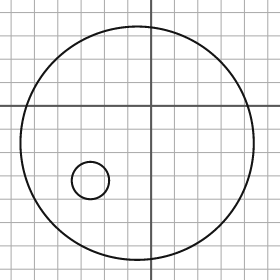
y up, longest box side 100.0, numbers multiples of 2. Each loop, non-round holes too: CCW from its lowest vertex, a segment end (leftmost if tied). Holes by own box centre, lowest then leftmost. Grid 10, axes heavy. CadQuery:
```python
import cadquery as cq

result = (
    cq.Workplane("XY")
    .moveTo(-6.0, -16.0)
    .circle(50.0)
    .moveTo(-26.0, -32.0)
    .circle(8.0)
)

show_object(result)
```